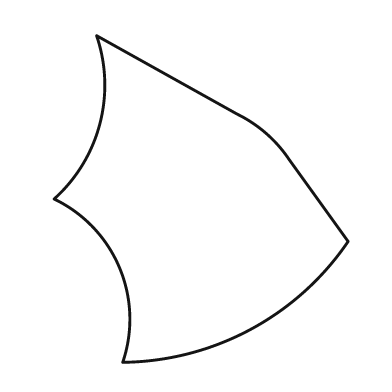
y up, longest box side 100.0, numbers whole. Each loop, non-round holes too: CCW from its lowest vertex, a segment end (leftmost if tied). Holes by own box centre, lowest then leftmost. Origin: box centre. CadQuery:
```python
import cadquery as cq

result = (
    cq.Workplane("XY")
    .moveTo(-24.0, -50.0)
    .threePointArc((15.0, -40.0), (45.0, -13.0))
    .lineTo(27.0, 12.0)
    .threePointArc((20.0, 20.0), (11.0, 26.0))
    .lineTo(-32.0, 50.0)
    .threePointArc((-31.0, 23.0), (-45.0, 0.0))
    .threePointArc((-25.0, -21.0), (-24.0, -50.0))
    .close()
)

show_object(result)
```